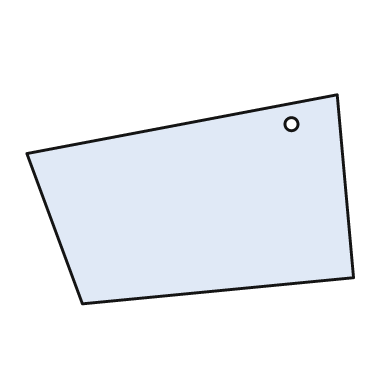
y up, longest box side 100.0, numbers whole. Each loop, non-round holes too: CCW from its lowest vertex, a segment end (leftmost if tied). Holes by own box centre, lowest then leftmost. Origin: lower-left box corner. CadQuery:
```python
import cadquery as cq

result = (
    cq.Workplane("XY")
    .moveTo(17.0, 0.0)
    .lineTo(100.0, 8.0)
    .lineTo(95.0, 64.0)
    .lineTo(0.0, 46.0)
    .close()
    .moveTo(81.0, 55.0)
    .circle(2.0)
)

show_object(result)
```